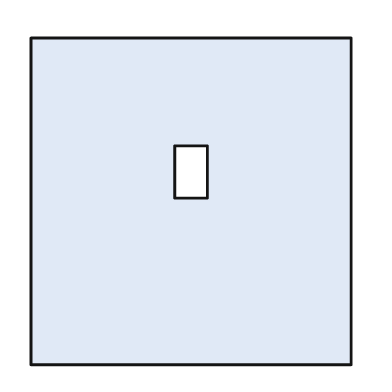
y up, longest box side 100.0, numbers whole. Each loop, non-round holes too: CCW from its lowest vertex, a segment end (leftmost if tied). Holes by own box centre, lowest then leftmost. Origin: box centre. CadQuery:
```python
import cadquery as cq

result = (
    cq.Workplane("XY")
    .moveTo(-49.0, -50.0)
    .lineTo(49.0, -50.0)
    .lineTo(49.0, 50.0)
    .lineTo(-49.0, 50.0)
    .close()
    .moveTo(-5.0, 1.0)
    .lineTo(5.0, 1.0)
    .lineTo(5.0, 17.0)
    .lineTo(-5.0, 17.0)
    .close()
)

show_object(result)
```